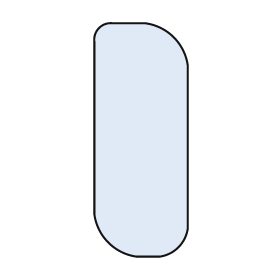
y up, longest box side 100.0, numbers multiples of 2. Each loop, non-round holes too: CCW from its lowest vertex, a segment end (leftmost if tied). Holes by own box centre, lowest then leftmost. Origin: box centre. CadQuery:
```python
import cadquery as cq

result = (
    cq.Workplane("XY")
    .moveTo(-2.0, -50.0)
    .lineTo(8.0, -50.0)
    .threePointArc((16.0, -46.0), (20.0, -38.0))
    .lineTo(20.0, 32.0)
    .threePointArc((14.0, 44.0), (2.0, 50.0))
    .lineTo(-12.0, 50.0)
    .threePointArc((-18.0, 48.0), (-20.0, 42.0))
    .lineTo(-20.0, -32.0)
    .threePointArc((-14.0, -44.0), (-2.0, -50.0))
    .close()
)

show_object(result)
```